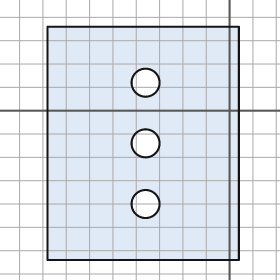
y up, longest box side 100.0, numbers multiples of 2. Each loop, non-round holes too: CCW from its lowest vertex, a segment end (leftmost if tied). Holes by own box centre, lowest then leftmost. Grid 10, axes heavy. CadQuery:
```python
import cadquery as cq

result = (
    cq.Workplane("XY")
    .moveTo(-78.0, -64.0)
    .lineTo(4.0, -64.0)
    .lineTo(4.0, 36.0)
    .lineTo(-78.0, 36.0)
    .close()
    .moveTo(-36.0, -40.0)
    .circle(6.0)
    .moveTo(-36.0, -14.0)
    .circle(6.0)
    .moveTo(-36.0, 12.0)
    .circle(6.0)
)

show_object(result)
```